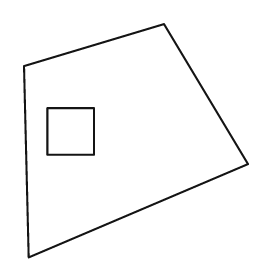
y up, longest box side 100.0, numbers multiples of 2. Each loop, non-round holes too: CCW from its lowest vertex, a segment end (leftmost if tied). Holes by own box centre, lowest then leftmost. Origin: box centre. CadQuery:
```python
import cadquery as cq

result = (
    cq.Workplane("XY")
    .moveTo(-46.0, -50.0)
    .lineTo(48.0, -10.0)
    .lineTo(12.0, 50.0)
    .lineTo(-48.0, 32.0)
    .close()
    .moveTo(-38.0, -6.0)
    .lineTo(-18.0, -6.0)
    .lineTo(-18.0, 14.0)
    .lineTo(-38.0, 14.0)
    .close()
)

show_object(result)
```